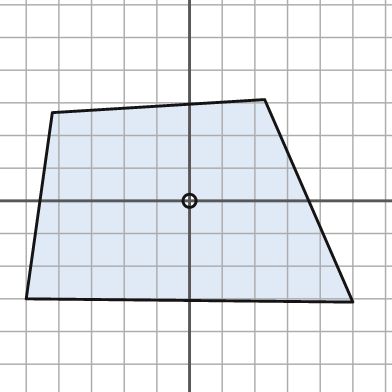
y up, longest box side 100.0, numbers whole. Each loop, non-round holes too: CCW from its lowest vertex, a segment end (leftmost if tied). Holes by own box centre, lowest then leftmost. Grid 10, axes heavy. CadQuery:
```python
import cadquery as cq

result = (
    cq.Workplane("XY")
    .moveTo(50.0, -31.0)
    .lineTo(23.0, 31.0)
    .lineTo(-42.0, 27.0)
    .lineTo(-50.0, -30.0)
    .close()
    .moveTo(0.0, 0.0)
    .circle(2.0)
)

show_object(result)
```